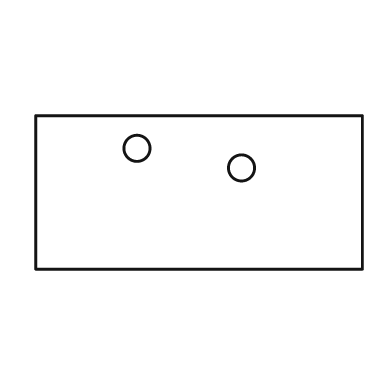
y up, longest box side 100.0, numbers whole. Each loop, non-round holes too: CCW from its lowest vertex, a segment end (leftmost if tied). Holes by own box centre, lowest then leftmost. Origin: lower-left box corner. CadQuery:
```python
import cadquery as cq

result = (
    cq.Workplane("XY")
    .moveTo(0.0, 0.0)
    .lineTo(100.0, 0.0)
    .lineTo(100.0, 47.0)
    .lineTo(0.0, 47.0)
    .close()
    .moveTo(63.0, 31.0)
    .circle(4.0)
    .moveTo(31.0, 37.0)
    .circle(4.0)
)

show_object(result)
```